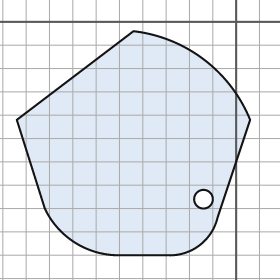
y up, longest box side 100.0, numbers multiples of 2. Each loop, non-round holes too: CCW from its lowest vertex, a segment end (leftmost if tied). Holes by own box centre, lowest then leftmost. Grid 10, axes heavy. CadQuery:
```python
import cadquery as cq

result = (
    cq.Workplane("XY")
    .moveTo(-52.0, -100.0)
    .lineTo(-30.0, -100.0)
    .threePointArc((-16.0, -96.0), (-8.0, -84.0))
    .lineTo(6.0, -42.0)
    .threePointArc((-14.0, -16.0), (-44.0, -4.0))
    .lineTo(-94.0, -42.0)
    .lineTo(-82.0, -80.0)
    .threePointArc((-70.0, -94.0), (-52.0, -100.0))
    .close()
    .moveTo(-14.0, -76.0)
    .circle(4.0)
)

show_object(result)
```